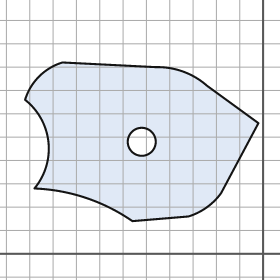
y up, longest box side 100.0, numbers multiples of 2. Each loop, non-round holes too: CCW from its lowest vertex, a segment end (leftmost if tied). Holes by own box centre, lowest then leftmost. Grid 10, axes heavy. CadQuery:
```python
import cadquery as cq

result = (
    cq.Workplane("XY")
    .moveTo(-56.0, 14.0)
    .lineTo(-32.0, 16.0)
    .threePointArc((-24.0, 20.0), (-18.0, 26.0))
    .lineTo(-2.0, 56.0)
    .lineTo(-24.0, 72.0)
    .threePointArc((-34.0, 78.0), (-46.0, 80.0))
    .lineTo(-86.0, 82.0)
    .threePointArc((-96.0, 76.0), (-102.0, 66.0))
    .threePointArc((-92.0, 48.0), (-98.0, 28.0))
    .threePointArc((-76.0, 24.0), (-56.0, 14.0))
    .close()
    .moveTo(-52.0, 48.0)
    .circle(6.0)
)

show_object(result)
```